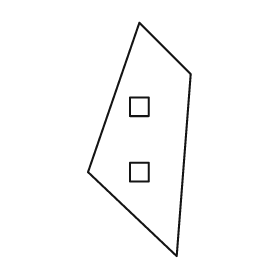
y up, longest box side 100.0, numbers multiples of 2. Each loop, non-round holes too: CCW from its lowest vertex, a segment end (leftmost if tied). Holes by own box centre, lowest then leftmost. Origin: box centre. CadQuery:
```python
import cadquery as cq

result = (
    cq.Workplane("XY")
    .moveTo(16.0, -50.0)
    .lineTo(22.0, 28.0)
    .lineTo(0.0, 50.0)
    .lineTo(-22.0, -14.0)
    .close()
    .moveTo(-4.0, -18.0)
    .lineTo(4.0, -18.0)
    .lineTo(4.0, -10.0)
    .lineTo(-4.0, -10.0)
    .close()
    .moveTo(-4.0, 10.0)
    .lineTo(4.0, 10.0)
    .lineTo(4.0, 18.0)
    .lineTo(-4.0, 18.0)
    .close()
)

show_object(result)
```